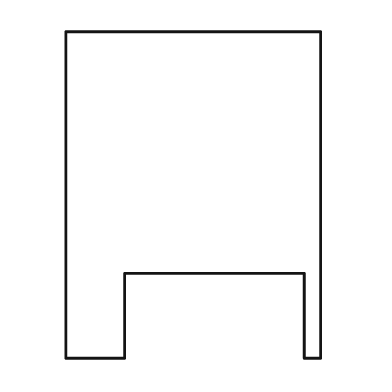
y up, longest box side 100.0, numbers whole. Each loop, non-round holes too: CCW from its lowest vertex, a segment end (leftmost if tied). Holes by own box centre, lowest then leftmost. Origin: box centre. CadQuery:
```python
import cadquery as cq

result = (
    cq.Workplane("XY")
    .moveTo(-39.0, -50.0)
    .lineTo(-21.0, -50.0)
    .lineTo(-21.0, -24.0)
    .lineTo(34.0, -24.0)
    .lineTo(34.0, -50.0)
    .lineTo(39.0, -50.0)
    .lineTo(39.0, 50.0)
    .lineTo(-39.0, 50.0)
    .close()
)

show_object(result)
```